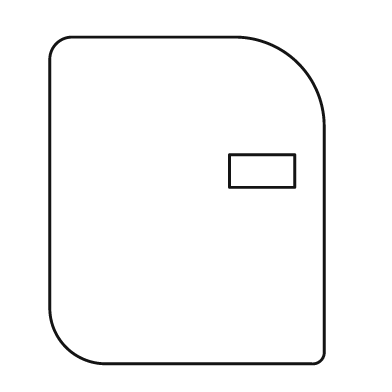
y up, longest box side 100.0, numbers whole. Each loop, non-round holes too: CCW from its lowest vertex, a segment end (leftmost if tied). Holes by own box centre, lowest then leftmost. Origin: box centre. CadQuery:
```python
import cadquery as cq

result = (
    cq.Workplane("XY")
    .moveTo(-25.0, -50.0)
    .lineTo(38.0, -50.0)
    .threePointArc((41.0, -49.0), (42.0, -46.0))
    .lineTo(42.0, 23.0)
    .threePointArc((34.0, 42.0), (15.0, 50.0))
    .lineTo(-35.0, 50.0)
    .threePointArc((-40.0, 48.0), (-42.0, 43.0))
    .lineTo(-42.0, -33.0)
    .threePointArc((-37.0, -45.0), (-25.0, -50.0))
    .close()
    .moveTo(13.0, 4.0)
    .lineTo(33.0, 4.0)
    .lineTo(33.0, 14.0)
    .lineTo(13.0, 14.0)
    .close()
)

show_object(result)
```